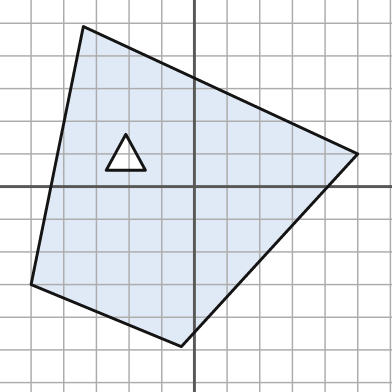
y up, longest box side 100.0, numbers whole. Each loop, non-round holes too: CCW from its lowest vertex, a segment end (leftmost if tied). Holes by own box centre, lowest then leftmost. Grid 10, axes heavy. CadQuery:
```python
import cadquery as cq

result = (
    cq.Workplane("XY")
    .moveTo(-4.0, -49.0)
    .lineTo(50.0, 10.0)
    .lineTo(-34.0, 49.0)
    .lineTo(-50.0, -30.0)
    .close()
    .moveTo(-27.0, 5.0)
    .lineTo(-15.0, 5.0)
    .lineTo(-21.0, 16.0)
    .close()
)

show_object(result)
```